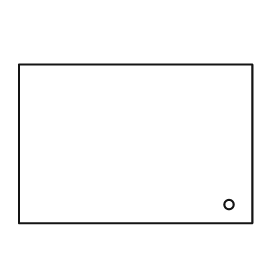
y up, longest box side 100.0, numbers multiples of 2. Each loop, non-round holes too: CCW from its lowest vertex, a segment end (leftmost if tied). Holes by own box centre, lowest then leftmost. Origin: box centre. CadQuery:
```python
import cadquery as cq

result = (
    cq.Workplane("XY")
    .moveTo(-50.0, -34.0)
    .lineTo(50.0, -34.0)
    .lineTo(50.0, 34.0)
    .lineTo(-50.0, 34.0)
    .close()
    .moveTo(40.0, -26.0)
    .circle(2.0)
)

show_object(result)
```